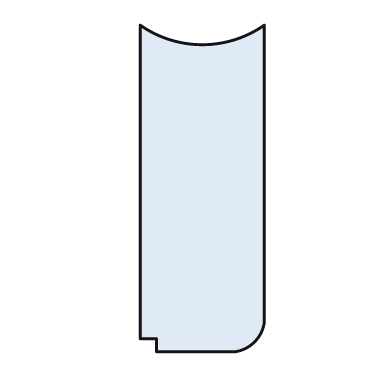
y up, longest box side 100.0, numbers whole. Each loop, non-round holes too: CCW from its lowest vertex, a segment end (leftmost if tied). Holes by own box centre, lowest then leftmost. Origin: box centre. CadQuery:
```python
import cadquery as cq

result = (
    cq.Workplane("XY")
    .moveTo(-14.0, -50.0)
    .lineTo(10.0, -50.0)
    .threePointArc((16.0, -47.0), (19.0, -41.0))
    .lineTo(19.0, 50.0)
    .threePointArc((0.0, 44.0), (-19.0, 50.0))
    .lineTo(-19.0, -46.0)
    .lineTo(-14.0, -46.0)
    .close()
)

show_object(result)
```